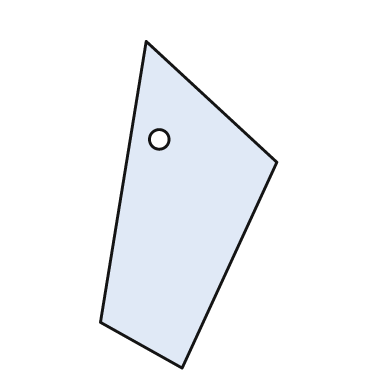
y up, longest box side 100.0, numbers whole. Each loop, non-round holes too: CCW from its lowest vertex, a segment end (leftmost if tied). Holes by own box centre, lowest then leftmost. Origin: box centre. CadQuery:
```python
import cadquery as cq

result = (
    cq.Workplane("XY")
    .moveTo(-2.0, -50.0)
    .lineTo(27.0, 13.0)
    .lineTo(-13.0, 50.0)
    .lineTo(-27.0, -36.0)
    .close()
    .moveTo(-9.0, 20.0)
    .circle(3.0)
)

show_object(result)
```